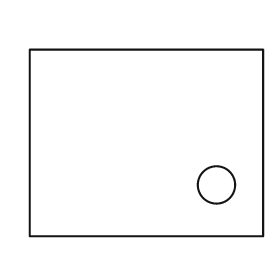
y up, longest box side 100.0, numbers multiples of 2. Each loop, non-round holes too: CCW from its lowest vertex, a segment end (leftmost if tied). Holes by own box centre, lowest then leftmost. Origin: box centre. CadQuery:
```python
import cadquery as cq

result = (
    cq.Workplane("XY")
    .moveTo(-50.0, -40.0)
    .lineTo(50.0, -40.0)
    .lineTo(50.0, 40.0)
    .lineTo(-50.0, 40.0)
    .close()
    .moveTo(30.0, -18.0)
    .circle(8.0)
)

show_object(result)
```